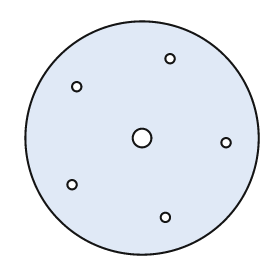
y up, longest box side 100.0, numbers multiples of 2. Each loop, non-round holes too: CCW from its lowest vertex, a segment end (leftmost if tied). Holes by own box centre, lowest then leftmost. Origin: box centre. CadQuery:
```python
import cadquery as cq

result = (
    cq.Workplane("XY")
    .moveTo(0.0, 0.0)
    .circle(50.0)
    .moveTo(10.0, -34.0)
    .circle(2.0)
    .moveTo(-30.0, -20.0)
    .circle(2.0)
    .moveTo(36.0, -2.0)
    .circle(2.0)
    .moveTo(0.0, 0.0)
    .circle(4.0)
    .moveTo(-28.0, 22.0)
    .circle(2.0)
    .moveTo(12.0, 34.0)
    .circle(2.0)
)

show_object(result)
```